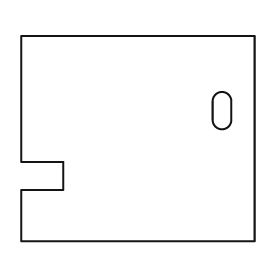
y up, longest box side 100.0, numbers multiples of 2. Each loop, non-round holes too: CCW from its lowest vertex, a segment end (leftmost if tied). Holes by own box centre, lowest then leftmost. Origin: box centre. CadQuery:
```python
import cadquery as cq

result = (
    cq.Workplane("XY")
    .moveTo(-50.0, -44.0)
    .lineTo(50.0, -44.0)
    .lineTo(50.0, 44.0)
    .lineTo(-50.0, 44.0)
    .lineTo(-50.0, -10.0)
    .lineTo(-32.0, -10.0)
    .lineTo(-32.0, -22.0)
    .lineTo(-50.0, -22.0)
    .close()
    .moveTo(32.0, 8.0)
    .threePointArc((36.0, 4.0), (40.0, 8.0))
    .lineTo(40.0, 16.0)
    .threePointArc((36.0, 20.0), (32.0, 16.0))
    .close()
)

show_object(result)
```